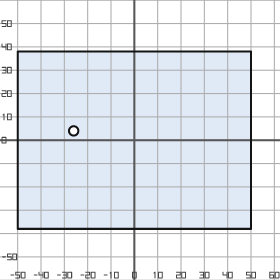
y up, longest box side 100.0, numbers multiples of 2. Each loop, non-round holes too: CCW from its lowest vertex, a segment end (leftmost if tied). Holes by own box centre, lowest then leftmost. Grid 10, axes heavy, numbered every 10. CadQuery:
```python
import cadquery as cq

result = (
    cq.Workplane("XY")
    .moveTo(-50.0, -38.0)
    .lineTo(50.0, -38.0)
    .lineTo(50.0, 38.0)
    .lineTo(-50.0, 38.0)
    .close()
    .moveTo(-26.0, 4.0)
    .circle(2.0)
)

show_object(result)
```